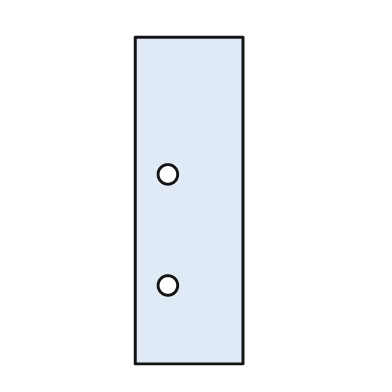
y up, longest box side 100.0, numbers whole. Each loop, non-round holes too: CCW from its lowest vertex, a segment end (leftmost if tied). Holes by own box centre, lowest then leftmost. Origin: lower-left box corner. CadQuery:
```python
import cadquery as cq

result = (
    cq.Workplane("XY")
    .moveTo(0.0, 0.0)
    .lineTo(33.0, 0.0)
    .lineTo(33.0, 100.0)
    .lineTo(0.0, 100.0)
    .close()
    .moveTo(10.0, 24.0)
    .circle(3.0)
    .moveTo(10.0, 58.0)
    .circle(3.0)
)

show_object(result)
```